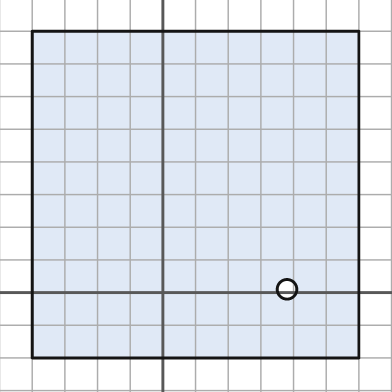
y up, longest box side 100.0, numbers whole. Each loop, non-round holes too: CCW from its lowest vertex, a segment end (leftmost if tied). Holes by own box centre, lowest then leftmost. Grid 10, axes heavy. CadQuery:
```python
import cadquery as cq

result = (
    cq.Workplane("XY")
    .moveTo(-40.0, -20.0)
    .lineTo(60.0, -20.0)
    .lineTo(60.0, 80.0)
    .lineTo(-40.0, 80.0)
    .close()
    .moveTo(38.0, 1.0)
    .circle(3.0)
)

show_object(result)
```